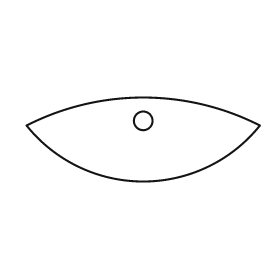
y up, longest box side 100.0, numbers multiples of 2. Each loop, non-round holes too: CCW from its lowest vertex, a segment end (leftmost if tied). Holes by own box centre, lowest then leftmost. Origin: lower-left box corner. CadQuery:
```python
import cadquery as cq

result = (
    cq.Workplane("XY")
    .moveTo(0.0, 24.0)
    .threePointArc((50.0, 0.0), (100.0, 24.0))
    .threePointArc((50.0, 36.0), (0.0, 24.0))
    .close()
    .moveTo(50.0, 26.0)
    .circle(4.0)
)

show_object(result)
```